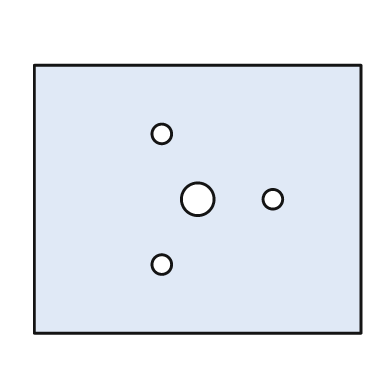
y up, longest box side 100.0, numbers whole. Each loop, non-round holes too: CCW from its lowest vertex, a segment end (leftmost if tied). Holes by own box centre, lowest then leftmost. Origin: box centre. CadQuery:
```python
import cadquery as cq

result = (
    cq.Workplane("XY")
    .moveTo(-50.0, -41.0)
    .lineTo(50.0, -41.0)
    .lineTo(50.0, 41.0)
    .lineTo(-50.0, 41.0)
    .close()
    .moveTo(-11.0, -20.0)
    .circle(3.0)
    .moveTo(0.0, 0.0)
    .circle(5.0)
    .moveTo(23.0, 0.0)
    .circle(3.0)
    .moveTo(-11.0, 20.0)
    .circle(3.0)
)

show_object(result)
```